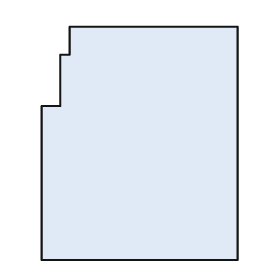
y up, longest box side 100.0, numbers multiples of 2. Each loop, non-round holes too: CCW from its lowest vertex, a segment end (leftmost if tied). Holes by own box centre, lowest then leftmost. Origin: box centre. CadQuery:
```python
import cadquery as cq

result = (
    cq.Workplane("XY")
    .moveTo(-42.0, -50.0)
    .lineTo(42.0, -50.0)
    .lineTo(42.0, 50.0)
    .lineTo(-30.0, 50.0)
    .lineTo(-30.0, 38.0)
    .lineTo(-34.0, 38.0)
    .lineTo(-34.0, 16.0)
    .lineTo(-42.0, 16.0)
    .close()
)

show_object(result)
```